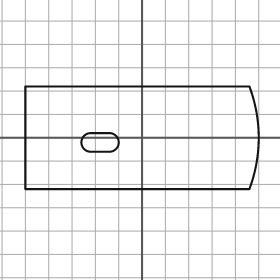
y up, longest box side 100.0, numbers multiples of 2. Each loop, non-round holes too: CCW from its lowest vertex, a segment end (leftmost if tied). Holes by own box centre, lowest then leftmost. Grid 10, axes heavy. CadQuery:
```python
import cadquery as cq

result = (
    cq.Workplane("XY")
    .moveTo(-50.0, -22.0)
    .lineTo(46.0, -22.0)
    .threePointArc((50.0, 0.0), (46.0, 22.0))
    .lineTo(-50.0, 22.0)
    .close()
    .moveTo(-22.0, -6.0)
    .lineTo(-14.0, -6.0)
    .threePointArc((-10.0, -2.0), (-14.0, 2.0))
    .lineTo(-22.0, 2.0)
    .threePointArc((-26.0, -2.0), (-22.0, -6.0))
    .close()
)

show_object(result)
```